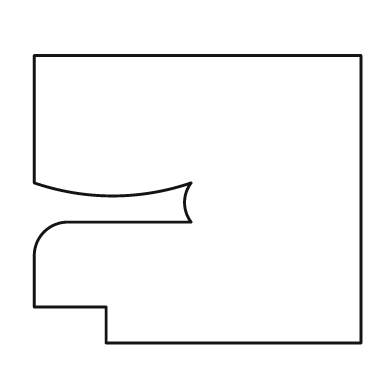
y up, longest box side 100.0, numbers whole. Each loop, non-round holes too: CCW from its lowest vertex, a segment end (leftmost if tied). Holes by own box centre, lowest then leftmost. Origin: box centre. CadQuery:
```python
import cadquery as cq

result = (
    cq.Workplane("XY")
    .moveTo(-28.0, -44.0)
    .lineTo(50.0, -44.0)
    .lineTo(50.0, 44.0)
    .lineTo(-50.0, 44.0)
    .lineTo(-50.0, 5.0)
    .threePointArc((-26.0, 1.0), (-2.0, 5.0))
    .threePointArc((-4.0, -1.0), (-2.0, -7.0))
    .lineTo(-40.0, -7.0)
    .threePointArc((-47.0, -10.0), (-50.0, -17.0))
    .lineTo(-50.0, -33.0)
    .lineTo(-28.0, -33.0)
    .close()
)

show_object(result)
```